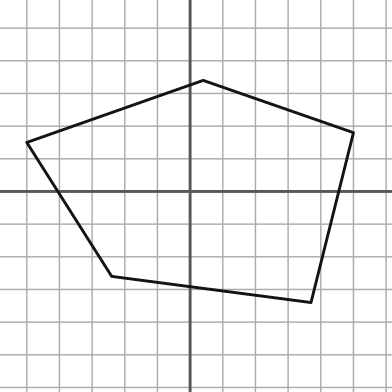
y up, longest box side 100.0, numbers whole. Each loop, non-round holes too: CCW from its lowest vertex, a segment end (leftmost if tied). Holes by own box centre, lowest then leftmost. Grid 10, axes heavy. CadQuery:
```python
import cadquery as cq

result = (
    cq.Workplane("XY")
    .moveTo(37.0, -34.0)
    .lineTo(50.0, 18.0)
    .lineTo(4.0, 34.0)
    .lineTo(-50.0, 15.0)
    .lineTo(-24.0, -26.0)
    .close()
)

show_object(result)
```